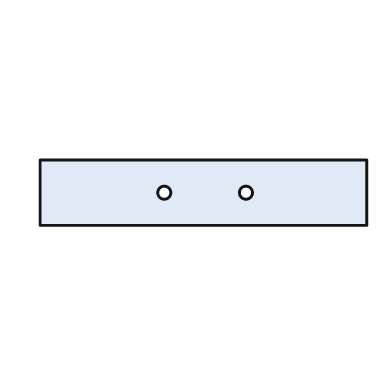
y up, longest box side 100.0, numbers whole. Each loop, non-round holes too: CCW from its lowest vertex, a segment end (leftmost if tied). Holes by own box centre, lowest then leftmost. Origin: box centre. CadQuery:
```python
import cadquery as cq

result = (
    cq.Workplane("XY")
    .moveTo(-50.0, -10.0)
    .lineTo(50.0, -10.0)
    .lineTo(50.0, 10.0)
    .lineTo(-50.0, 10.0)
    .close()
    .moveTo(-12.0, 0.0)
    .circle(2.0)
    .moveTo(13.0, 0.0)
    .circle(2.0)
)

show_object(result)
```